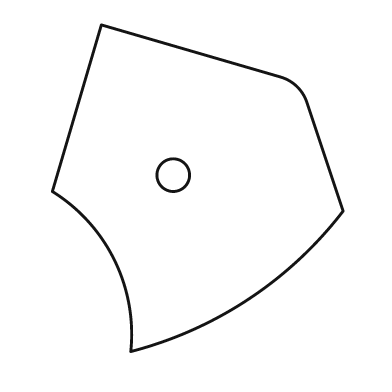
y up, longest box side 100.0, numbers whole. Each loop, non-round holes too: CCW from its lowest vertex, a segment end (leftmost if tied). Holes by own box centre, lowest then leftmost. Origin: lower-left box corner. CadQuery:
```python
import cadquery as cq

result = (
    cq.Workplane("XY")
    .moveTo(24.0, 0.0)
    .threePointArc((60.0, 16.0), (89.0, 43.0))
    .lineTo(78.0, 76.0)
    .threePointArc((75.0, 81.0), (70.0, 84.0))
    .lineTo(15.0, 100.0)
    .lineTo(0.0, 49.0)
    .threePointArc((19.0, 28.0), (24.0, 0.0))
    .close()
    .moveTo(37.0, 54.0)
    .circle(5.0)
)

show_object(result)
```